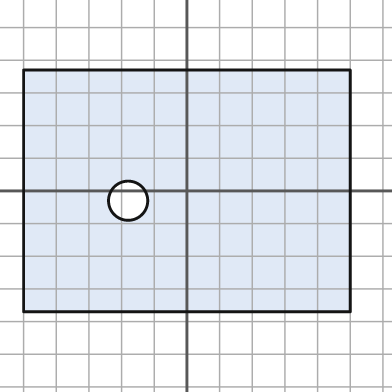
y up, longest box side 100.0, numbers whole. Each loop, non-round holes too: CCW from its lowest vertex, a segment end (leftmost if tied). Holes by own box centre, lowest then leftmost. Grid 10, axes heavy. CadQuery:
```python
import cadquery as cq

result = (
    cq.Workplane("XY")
    .moveTo(-50.0, -37.0)
    .lineTo(50.0, -37.0)
    .lineTo(50.0, 37.0)
    .lineTo(-50.0, 37.0)
    .close()
    .moveTo(-18.0, -3.0)
    .circle(6.0)
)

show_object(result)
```